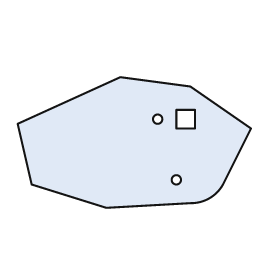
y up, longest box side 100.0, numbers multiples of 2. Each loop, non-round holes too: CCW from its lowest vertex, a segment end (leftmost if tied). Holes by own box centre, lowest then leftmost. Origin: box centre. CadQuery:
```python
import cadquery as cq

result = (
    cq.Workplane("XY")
    .moveTo(-12.0, -28.0)
    .lineTo(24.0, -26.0)
    .threePointArc((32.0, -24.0), (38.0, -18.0))
    .lineTo(50.0, 6.0)
    .lineTo(24.0, 24.0)
    .lineTo(-6.0, 28.0)
    .lineTo(-50.0, 8.0)
    .lineTo(-44.0, -18.0)
    .close()
    .moveTo(18.0, -16.0)
    .circle(2.0)
    .moveTo(10.0, 10.0)
    .circle(2.0)
    .moveTo(18.0, 6.0)
    .lineTo(26.0, 6.0)
    .lineTo(26.0, 14.0)
    .lineTo(18.0, 14.0)
    .close()
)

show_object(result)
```